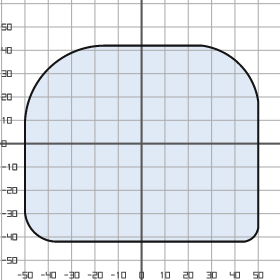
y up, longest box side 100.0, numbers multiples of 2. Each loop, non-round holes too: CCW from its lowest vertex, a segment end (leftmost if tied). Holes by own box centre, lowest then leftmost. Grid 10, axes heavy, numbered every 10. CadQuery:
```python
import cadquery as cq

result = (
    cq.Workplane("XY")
    .moveTo(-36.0, -42.0)
    .lineTo(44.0, -42.0)
    .threePointArc((48.0, -40.0), (50.0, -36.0))
    .lineTo(50.0, 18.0)
    .threePointArc((42.0, 34.0), (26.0, 42.0))
    .lineTo(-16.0, 42.0)
    .threePointArc((-40.0, 32.0), (-50.0, 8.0))
    .lineTo(-50.0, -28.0)
    .threePointArc((-46.0, -38.0), (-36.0, -42.0))
    .close()
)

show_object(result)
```